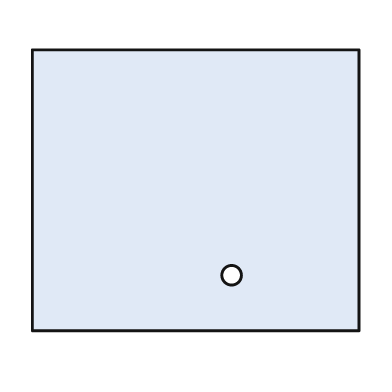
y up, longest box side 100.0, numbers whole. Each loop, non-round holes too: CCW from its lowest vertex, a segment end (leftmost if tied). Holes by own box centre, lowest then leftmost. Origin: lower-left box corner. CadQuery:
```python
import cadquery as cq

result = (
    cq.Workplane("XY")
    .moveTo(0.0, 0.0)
    .lineTo(100.0, 0.0)
    .lineTo(100.0, 86.0)
    .lineTo(0.0, 86.0)
    .close()
    .moveTo(61.0, 17.0)
    .circle(3.0)
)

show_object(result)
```